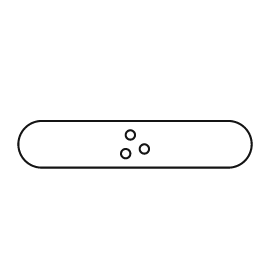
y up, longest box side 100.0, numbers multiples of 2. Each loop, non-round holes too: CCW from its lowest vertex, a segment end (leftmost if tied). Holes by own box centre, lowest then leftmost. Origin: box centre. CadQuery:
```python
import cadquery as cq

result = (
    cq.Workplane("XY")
    .moveTo(-40.0, -10.0)
    .lineTo(40.0, -10.0)
    .threePointArc((50.0, 0.0), (40.0, 10.0))
    .lineTo(-40.0, 10.0)
    .threePointArc((-50.0, 0.0), (-40.0, -10.0))
    .close()
    .moveTo(-4.0, -4.0)
    .circle(2.0)
    .moveTo(4.0, -2.0)
    .circle(2.0)
    .moveTo(-2.0, 4.0)
    .circle(2.0)
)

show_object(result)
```